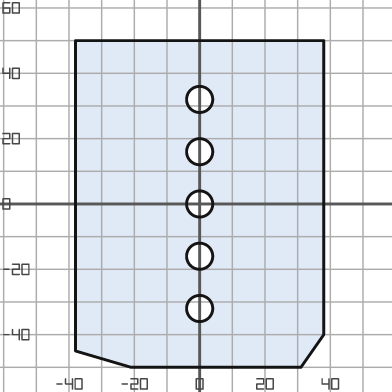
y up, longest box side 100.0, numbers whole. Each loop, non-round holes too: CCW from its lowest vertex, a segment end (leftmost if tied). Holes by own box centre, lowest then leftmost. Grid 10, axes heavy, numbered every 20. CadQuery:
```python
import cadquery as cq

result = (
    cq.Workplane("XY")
    .moveTo(-21.0, -50.0)
    .lineTo(31.0, -50.0)
    .lineTo(38.0, -40.0)
    .lineTo(38.0, 50.0)
    .lineTo(-38.0, 50.0)
    .lineTo(-38.0, -45.0)
    .close()
    .moveTo(0.0, -32.0)
    .circle(4.0)
    .moveTo(0.0, -16.0)
    .circle(4.0)
    .moveTo(0.0, 0.0)
    .circle(4.0)
    .moveTo(0.0, 16.0)
    .circle(4.0)
    .moveTo(0.0, 32.0)
    .circle(4.0)
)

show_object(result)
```